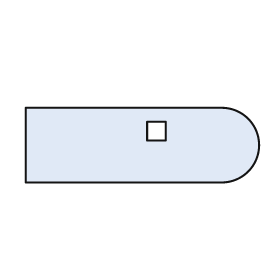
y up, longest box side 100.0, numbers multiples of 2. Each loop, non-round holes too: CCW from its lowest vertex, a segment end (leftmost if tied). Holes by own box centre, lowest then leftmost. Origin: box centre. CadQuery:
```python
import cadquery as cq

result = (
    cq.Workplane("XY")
    .moveTo(-50.0, -16.0)
    .lineTo(34.0, -16.0)
    .threePointArc((50.0, 0.0), (34.0, 16.0))
    .lineTo(-50.0, 16.0)
    .close()
    .moveTo(2.0, 2.0)
    .lineTo(10.0, 2.0)
    .lineTo(10.0, 10.0)
    .lineTo(2.0, 10.0)
    .close()
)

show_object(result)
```